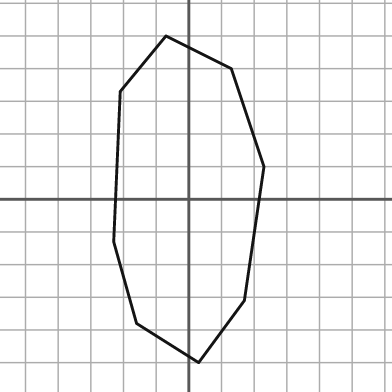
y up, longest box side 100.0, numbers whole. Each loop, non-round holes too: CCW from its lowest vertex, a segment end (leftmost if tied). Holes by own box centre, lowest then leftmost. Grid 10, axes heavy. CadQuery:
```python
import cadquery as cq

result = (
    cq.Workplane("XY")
    .moveTo(3.0, -50.0)
    .lineTo(17.0, -31.0)
    .lineTo(23.0, 10.0)
    .lineTo(13.0, 40.0)
    .lineTo(-7.0, 50.0)
    .lineTo(-21.0, 33.0)
    .lineTo(-23.0, -13.0)
    .lineTo(-16.0, -38.0)
    .close()
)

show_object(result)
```